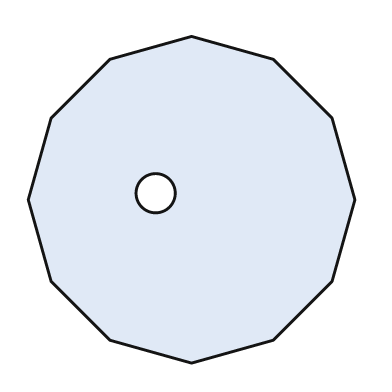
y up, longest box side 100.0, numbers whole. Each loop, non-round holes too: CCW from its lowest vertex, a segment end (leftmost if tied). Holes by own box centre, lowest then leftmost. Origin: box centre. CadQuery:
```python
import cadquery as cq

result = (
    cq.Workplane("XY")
    .moveTo(0.0, -50.0)
    .lineTo(25.0, -43.0)
    .lineTo(43.0, -25.0)
    .lineTo(50.0, 0.0)
    .lineTo(43.0, 25.0)
    .lineTo(25.0, 43.0)
    .lineTo(0.0, 50.0)
    .lineTo(-25.0, 43.0)
    .lineTo(-43.0, 25.0)
    .lineTo(-50.0, 0.0)
    .lineTo(-43.0, -25.0)
    .lineTo(-25.0, -43.0)
    .close()
    .moveTo(-11.0, 2.0)
    .circle(6.0)
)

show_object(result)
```